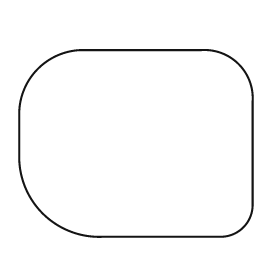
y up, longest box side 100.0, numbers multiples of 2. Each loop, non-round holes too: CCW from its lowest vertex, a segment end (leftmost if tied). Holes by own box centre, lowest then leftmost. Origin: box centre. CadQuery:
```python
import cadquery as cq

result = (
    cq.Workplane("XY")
    .moveTo(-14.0, -40.0)
    .lineTo(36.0, -40.0)
    .threePointArc((46.0, -36.0), (50.0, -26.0))
    .lineTo(50.0, 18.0)
    .threePointArc((44.0, 34.0), (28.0, 40.0))
    .lineTo(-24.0, 40.0)
    .threePointArc((-42.0, 32.0), (-50.0, 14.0))
    .lineTo(-50.0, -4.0)
    .threePointArc((-40.0, -30.0), (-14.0, -40.0))
    .close()
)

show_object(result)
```